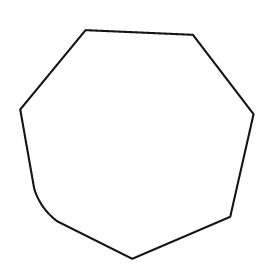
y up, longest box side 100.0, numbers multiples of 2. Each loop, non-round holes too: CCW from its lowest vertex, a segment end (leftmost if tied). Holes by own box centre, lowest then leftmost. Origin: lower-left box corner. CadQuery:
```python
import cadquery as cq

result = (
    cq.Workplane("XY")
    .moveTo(48.0, 0.0)
    .lineTo(90.0, 18.0)
    .lineTo(100.0, 62.0)
    .lineTo(74.0, 96.0)
    .lineTo(28.0, 98.0)
    .lineTo(0.0, 64.0)
    .lineTo(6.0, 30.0)
    .threePointArc((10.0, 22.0), (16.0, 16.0))
    .close()
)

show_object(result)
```